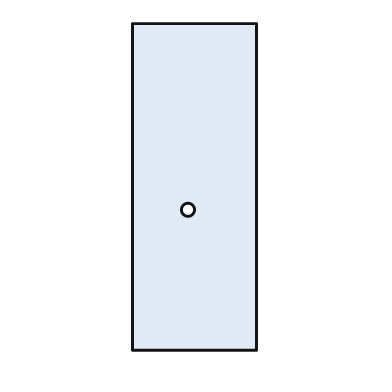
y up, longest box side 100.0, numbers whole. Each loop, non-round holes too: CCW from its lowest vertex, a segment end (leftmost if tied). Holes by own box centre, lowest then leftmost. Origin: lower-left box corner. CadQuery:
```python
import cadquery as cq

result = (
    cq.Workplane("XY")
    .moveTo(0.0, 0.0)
    .lineTo(38.0, 0.0)
    .lineTo(38.0, 100.0)
    .lineTo(0.0, 100.0)
    .close()
    .moveTo(17.0, 43.0)
    .circle(2.0)
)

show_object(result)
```